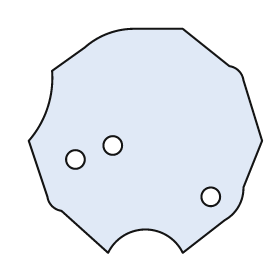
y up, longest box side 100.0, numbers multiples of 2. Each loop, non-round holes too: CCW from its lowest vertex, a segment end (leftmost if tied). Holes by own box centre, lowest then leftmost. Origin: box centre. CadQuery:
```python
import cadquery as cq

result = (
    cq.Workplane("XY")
    .moveTo(-16.0, -48.0)
    .threePointArc((0.0, -38.0), (16.0, -48.0))
    .lineTo(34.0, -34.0)
    .threePointArc((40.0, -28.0), (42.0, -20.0))
    .lineTo(50.0, 0.0)
    .lineTo(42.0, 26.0)
    .threePointArc((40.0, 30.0), (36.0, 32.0))
    .lineTo(16.0, 48.0)
    .lineTo(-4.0, 48.0)
    .threePointArc((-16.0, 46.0), (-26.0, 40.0))
    .lineTo(-40.0, 30.0)
    .threePointArc((-42.0, 14.0), (-50.0, 0.0))
    .lineTo(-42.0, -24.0)
    .threePointArc((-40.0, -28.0), (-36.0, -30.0))
    .close()
    .moveTo(28.0, -24.0)
    .circle(4.0)
    .moveTo(-30.0, -8.0)
    .circle(4.0)
    .moveTo(-14.0, -2.0)
    .circle(4.0)
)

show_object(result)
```